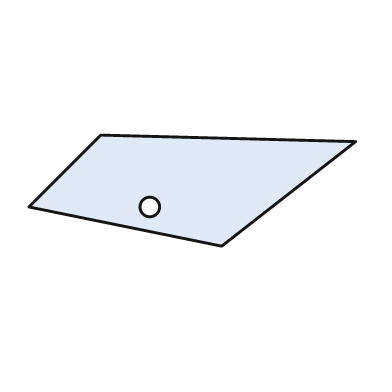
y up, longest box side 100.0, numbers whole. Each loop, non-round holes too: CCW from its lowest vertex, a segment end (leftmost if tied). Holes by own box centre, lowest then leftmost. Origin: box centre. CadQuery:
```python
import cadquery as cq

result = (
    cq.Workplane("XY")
    .moveTo(9.0, -17.0)
    .lineTo(50.0, 15.0)
    .lineTo(-28.0, 17.0)
    .lineTo(-50.0, -5.0)
    .close()
    .moveTo(-13.0, -5.0)
    .circle(3.0)
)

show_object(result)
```